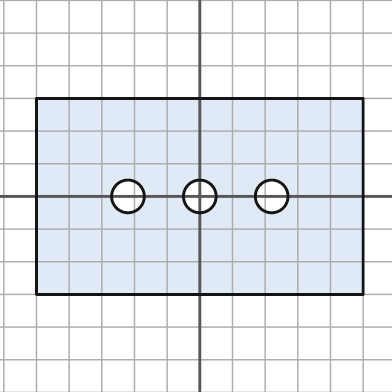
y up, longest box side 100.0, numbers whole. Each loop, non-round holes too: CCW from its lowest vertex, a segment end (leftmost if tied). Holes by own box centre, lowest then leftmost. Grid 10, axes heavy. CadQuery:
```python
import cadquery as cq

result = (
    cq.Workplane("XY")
    .moveTo(-50.0, -30.0)
    .lineTo(50.0, -30.0)
    .lineTo(50.0, 30.0)
    .lineTo(-50.0, 30.0)
    .close()
    .moveTo(-22.0, 0.0)
    .circle(5.0)
    .moveTo(0.0, 0.0)
    .circle(5.0)
    .moveTo(22.0, 0.0)
    .circle(5.0)
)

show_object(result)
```